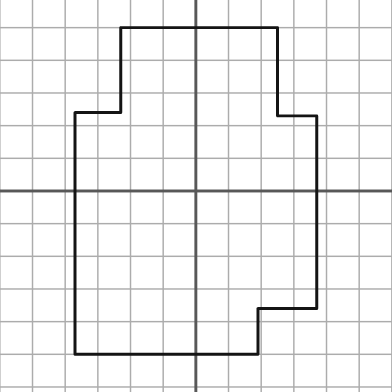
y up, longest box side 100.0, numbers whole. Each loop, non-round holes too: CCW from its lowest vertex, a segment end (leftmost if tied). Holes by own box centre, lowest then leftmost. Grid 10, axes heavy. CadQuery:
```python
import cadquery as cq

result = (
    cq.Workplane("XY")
    .moveTo(-37.0, -50.0)
    .lineTo(19.0, -50.0)
    .lineTo(19.0, -36.0)
    .lineTo(37.0, -36.0)
    .lineTo(37.0, 23.0)
    .lineTo(25.0, 23.0)
    .lineTo(25.0, 50.0)
    .lineTo(-23.0, 50.0)
    .lineTo(-23.0, 24.0)
    .lineTo(-37.0, 24.0)
    .close()
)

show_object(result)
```